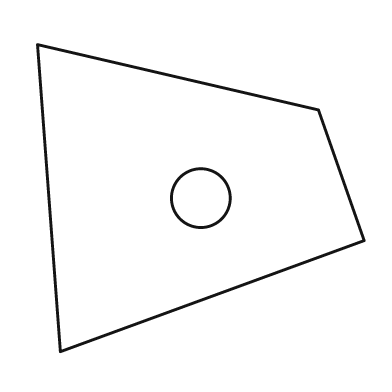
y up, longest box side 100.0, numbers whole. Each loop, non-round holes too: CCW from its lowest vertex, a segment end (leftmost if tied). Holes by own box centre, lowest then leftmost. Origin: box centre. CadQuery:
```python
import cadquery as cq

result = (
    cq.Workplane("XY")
    .moveTo(-43.0, -47.0)
    .lineTo(50.0, -13.0)
    .lineTo(36.0, 27.0)
    .lineTo(-50.0, 47.0)
    .close()
    .moveTo(0.0, 0.0)
    .circle(9.0)
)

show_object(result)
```